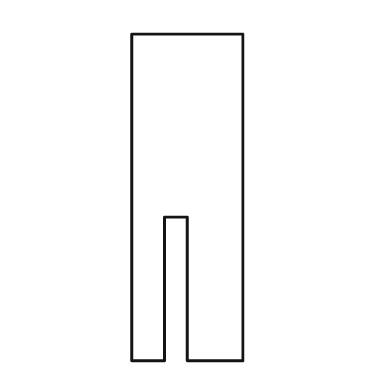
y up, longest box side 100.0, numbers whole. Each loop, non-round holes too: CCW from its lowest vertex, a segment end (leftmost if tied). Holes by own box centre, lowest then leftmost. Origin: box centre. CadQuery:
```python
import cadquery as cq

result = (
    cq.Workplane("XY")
    .moveTo(-17.0, -50.0)
    .lineTo(-7.0, -50.0)
    .lineTo(-7.0, -6.0)
    .lineTo(0.0, -6.0)
    .lineTo(0.0, -50.0)
    .lineTo(17.0, -50.0)
    .lineTo(17.0, 50.0)
    .lineTo(-17.0, 50.0)
    .close()
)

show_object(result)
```